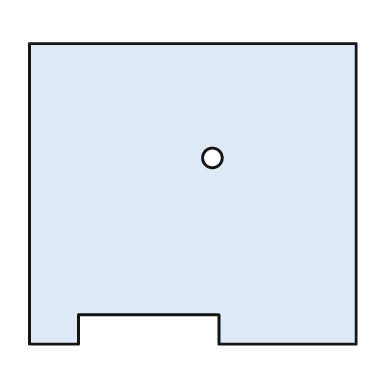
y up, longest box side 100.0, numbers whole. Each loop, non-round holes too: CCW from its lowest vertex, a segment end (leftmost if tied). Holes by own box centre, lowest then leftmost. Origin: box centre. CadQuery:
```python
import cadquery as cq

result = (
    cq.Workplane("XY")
    .moveTo(-50.0, -46.0)
    .lineTo(-35.0, -46.0)
    .lineTo(-35.0, -37.0)
    .lineTo(8.0, -37.0)
    .lineTo(8.0, -46.0)
    .lineTo(50.0, -46.0)
    .lineTo(50.0, 46.0)
    .lineTo(-50.0, 46.0)
    .close()
    .moveTo(6.0, 11.0)
    .circle(3.0)
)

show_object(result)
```